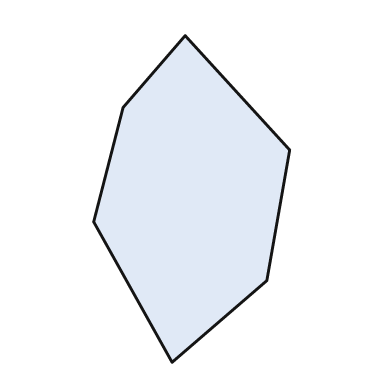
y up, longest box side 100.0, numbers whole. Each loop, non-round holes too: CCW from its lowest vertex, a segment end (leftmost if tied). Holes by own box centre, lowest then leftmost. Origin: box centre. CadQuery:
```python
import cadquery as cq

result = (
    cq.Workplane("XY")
    .moveTo(-6.0, -50.0)
    .lineTo(23.0, -25.0)
    .lineTo(30.0, 15.0)
    .lineTo(-2.0, 50.0)
    .lineTo(-21.0, 28.0)
    .lineTo(-30.0, -7.0)
    .close()
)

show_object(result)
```